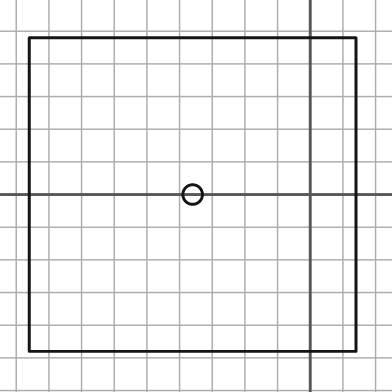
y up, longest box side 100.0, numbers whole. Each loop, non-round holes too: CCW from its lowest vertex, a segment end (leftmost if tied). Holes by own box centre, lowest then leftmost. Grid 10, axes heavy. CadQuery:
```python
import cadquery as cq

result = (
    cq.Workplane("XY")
    .moveTo(-86.0, -48.0)
    .lineTo(14.0, -48.0)
    .lineTo(14.0, 48.0)
    .lineTo(-86.0, 48.0)
    .close()
    .moveTo(-36.0, 0.0)
    .circle(3.0)
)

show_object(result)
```